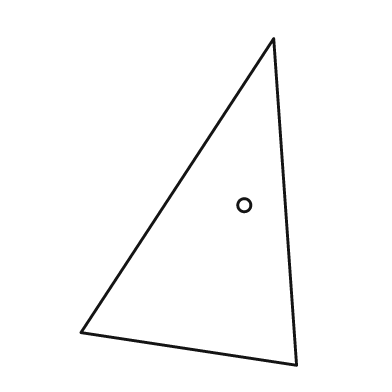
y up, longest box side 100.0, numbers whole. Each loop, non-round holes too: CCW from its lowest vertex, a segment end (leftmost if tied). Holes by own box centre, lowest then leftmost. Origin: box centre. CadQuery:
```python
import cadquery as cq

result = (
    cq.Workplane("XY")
    .moveTo(33.0, -50.0)
    .lineTo(26.0, 50.0)
    .lineTo(-33.0, -40.0)
    .close()
    .moveTo(17.0, -1.0)
    .circle(2.0)
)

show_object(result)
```